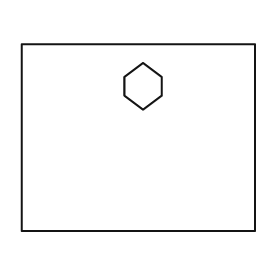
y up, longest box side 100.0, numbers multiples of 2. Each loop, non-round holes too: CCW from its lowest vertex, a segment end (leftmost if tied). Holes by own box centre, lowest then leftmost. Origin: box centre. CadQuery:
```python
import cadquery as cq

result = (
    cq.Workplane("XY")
    .moveTo(-50.0, -40.0)
    .lineTo(50.0, -40.0)
    .lineTo(50.0, 40.0)
    .lineTo(-50.0, 40.0)
    .close()
    .moveTo(2.0, 12.0)
    .lineTo(10.0, 18.0)
    .lineTo(10.0, 26.0)
    .lineTo(2.0, 32.0)
    .lineTo(-6.0, 26.0)
    .lineTo(-6.0, 18.0)
    .close()
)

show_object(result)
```